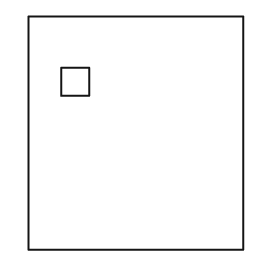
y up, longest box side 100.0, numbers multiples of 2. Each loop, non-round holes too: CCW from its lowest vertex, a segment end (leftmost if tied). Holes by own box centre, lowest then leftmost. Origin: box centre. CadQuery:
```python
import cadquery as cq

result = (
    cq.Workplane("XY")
    .moveTo(-46.0, -50.0)
    .lineTo(46.0, -50.0)
    .lineTo(46.0, 50.0)
    .lineTo(-46.0, 50.0)
    .close()
    .moveTo(-32.0, 16.0)
    .lineTo(-20.0, 16.0)
    .lineTo(-20.0, 28.0)
    .lineTo(-32.0, 28.0)
    .close()
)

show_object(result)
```